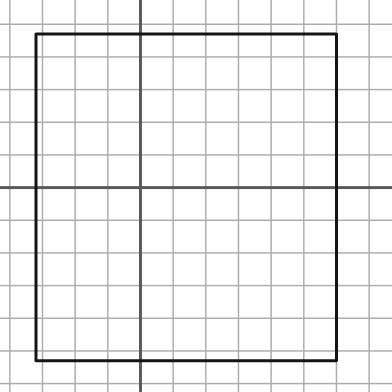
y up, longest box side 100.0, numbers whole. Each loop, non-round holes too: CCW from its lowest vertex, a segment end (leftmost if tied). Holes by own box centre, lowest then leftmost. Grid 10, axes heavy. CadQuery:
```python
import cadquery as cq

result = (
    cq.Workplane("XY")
    .moveTo(-32.0, -53.0)
    .lineTo(60.0, -53.0)
    .lineTo(60.0, 47.0)
    .lineTo(-32.0, 47.0)
    .close()
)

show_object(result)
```